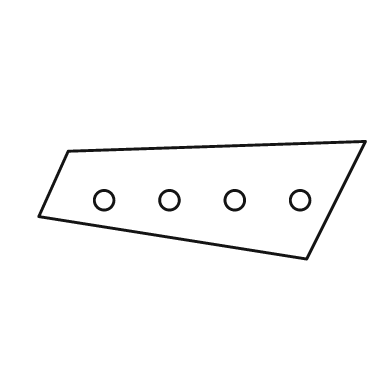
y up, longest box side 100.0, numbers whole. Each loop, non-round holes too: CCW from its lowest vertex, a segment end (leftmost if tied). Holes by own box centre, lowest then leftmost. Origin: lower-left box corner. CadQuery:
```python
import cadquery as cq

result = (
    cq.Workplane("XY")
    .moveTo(82.0, 0.0)
    .lineTo(100.0, 36.0)
    .lineTo(9.0, 33.0)
    .lineTo(0.0, 13.0)
    .close()
    .moveTo(20.0, 18.0)
    .circle(3.0)
    .moveTo(40.0, 18.0)
    .circle(3.0)
    .moveTo(60.0, 18.0)
    .circle(3.0)
    .moveTo(80.0, 18.0)
    .circle(3.0)
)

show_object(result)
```